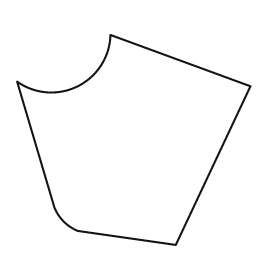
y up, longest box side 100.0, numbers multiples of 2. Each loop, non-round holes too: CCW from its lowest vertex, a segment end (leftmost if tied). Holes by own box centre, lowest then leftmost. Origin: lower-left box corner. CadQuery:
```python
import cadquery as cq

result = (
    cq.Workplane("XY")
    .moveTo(68.0, 0.0)
    .lineTo(100.0, 68.0)
    .lineTo(40.0, 90.0)
    .threePointArc((26.0, 68.0), (0.0, 70.0))
    .lineTo(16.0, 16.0)
    .threePointArc((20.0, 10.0), (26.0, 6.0))
    .close()
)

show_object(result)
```